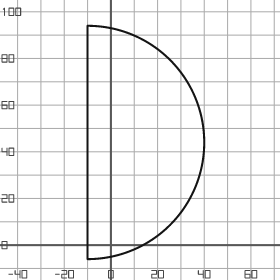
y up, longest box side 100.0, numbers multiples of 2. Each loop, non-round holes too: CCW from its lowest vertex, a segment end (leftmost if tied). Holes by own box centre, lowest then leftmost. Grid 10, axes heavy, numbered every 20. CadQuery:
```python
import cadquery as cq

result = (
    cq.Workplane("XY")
    .moveTo(-10.0, -6.0)
    .threePointArc((40.0, 44.0), (-10.0, 94.0))
    .close()
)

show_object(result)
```